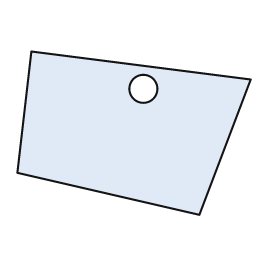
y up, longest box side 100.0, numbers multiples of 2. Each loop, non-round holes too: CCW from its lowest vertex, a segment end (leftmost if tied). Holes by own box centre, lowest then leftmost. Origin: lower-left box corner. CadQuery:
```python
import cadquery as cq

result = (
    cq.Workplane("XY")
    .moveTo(78.0, 0.0)
    .lineTo(100.0, 58.0)
    .lineTo(6.0, 70.0)
    .lineTo(0.0, 18.0)
    .close()
    .moveTo(54.0, 54.0)
    .circle(6.0)
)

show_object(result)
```